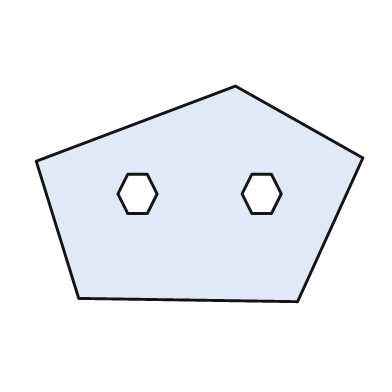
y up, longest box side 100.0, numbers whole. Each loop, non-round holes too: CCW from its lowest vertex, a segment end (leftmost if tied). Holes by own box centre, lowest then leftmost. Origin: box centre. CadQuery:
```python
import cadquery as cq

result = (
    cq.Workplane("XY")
    .moveTo(30.0, -33.0)
    .lineTo(50.0, 11.0)
    .lineTo(11.0, 33.0)
    .lineTo(-50.0, 10.0)
    .lineTo(-37.0, -32.0)
    .close()
    .moveTo(-22.0, -6.0)
    .lineTo(-16.0, -6.0)
    .lineTo(-13.0, 0.0)
    .lineTo(-16.0, 6.0)
    .lineTo(-22.0, 6.0)
    .lineTo(-25.0, 0.0)
    .close()
    .moveTo(16.0, -6.0)
    .lineTo(22.0, -6.0)
    .lineTo(25.0, 0.0)
    .lineTo(22.0, 6.0)
    .lineTo(16.0, 6.0)
    .lineTo(13.0, 0.0)
    .close()
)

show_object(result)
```